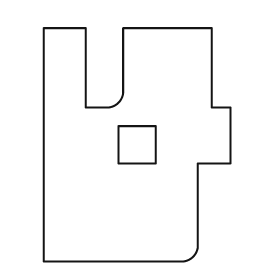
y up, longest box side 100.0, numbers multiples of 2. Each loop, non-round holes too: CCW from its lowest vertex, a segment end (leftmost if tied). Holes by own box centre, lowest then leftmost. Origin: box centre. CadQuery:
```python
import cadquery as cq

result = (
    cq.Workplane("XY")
    .moveTo(-40.0, -50.0)
    .lineTo(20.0, -50.0)
    .threePointArc((24.0, -48.0), (26.0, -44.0))
    .lineTo(26.0, -8.0)
    .lineTo(40.0, -8.0)
    .lineTo(40.0, 16.0)
    .lineTo(32.0, 16.0)
    .lineTo(32.0, 50.0)
    .lineTo(-6.0, 50.0)
    .lineTo(-6.0, 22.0)
    .threePointArc((-8.0, 18.0), (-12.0, 16.0))
    .lineTo(-22.0, 16.0)
    .lineTo(-22.0, 50.0)
    .lineTo(-40.0, 50.0)
    .close()
    .moveTo(-8.0, -8.0)
    .lineTo(8.0, -8.0)
    .lineTo(8.0, 8.0)
    .lineTo(-8.0, 8.0)
    .close()
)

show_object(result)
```